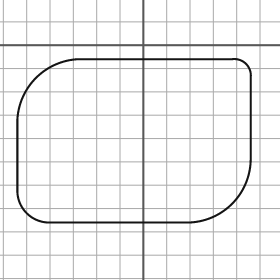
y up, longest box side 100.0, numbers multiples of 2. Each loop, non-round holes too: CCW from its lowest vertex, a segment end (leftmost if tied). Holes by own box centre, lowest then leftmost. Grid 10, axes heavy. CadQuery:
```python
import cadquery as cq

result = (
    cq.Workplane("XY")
    .moveTo(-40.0, -76.0)
    .lineTo(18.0, -76.0)
    .threePointArc((38.0, -68.0), (46.0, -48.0))
    .lineTo(46.0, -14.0)
    .threePointArc((44.0, -8.0), (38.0, -6.0))
    .lineTo(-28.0, -6.0)
    .threePointArc((-46.0, -14.0), (-54.0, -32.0))
    .lineTo(-54.0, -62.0)
    .threePointArc((-50.0, -72.0), (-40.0, -76.0))
    .close()
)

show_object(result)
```